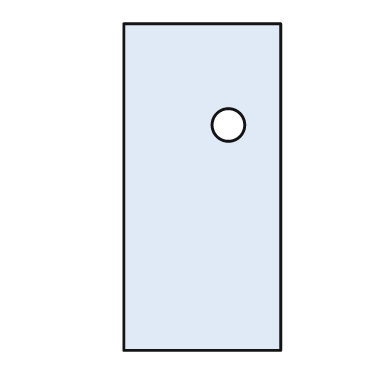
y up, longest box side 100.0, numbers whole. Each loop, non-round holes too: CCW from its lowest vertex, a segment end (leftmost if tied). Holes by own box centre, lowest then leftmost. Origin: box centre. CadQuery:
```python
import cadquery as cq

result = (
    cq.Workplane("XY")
    .moveTo(-24.0, -50.0)
    .lineTo(24.0, -50.0)
    .lineTo(24.0, 50.0)
    .lineTo(-24.0, 50.0)
    .close()
    .moveTo(8.0, 19.0)
    .circle(5.0)
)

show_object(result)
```